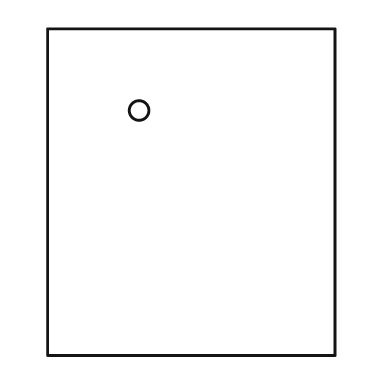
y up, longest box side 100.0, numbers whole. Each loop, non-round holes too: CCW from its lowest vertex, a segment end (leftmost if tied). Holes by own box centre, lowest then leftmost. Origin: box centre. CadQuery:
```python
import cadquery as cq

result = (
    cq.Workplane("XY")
    .moveTo(-44.0, -50.0)
    .lineTo(44.0, -50.0)
    .lineTo(44.0, 50.0)
    .lineTo(-44.0, 50.0)
    .close()
    .moveTo(-16.0, 25.0)
    .circle(3.0)
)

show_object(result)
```